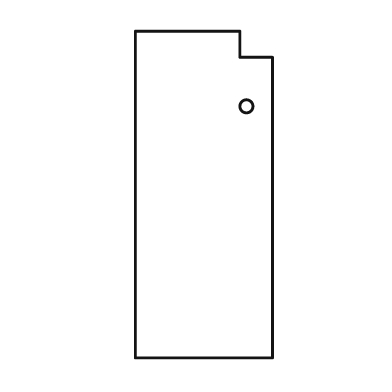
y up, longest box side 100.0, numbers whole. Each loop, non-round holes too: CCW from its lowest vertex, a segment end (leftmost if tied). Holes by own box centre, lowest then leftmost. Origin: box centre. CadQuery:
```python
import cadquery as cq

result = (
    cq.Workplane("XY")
    .moveTo(-21.0, -50.0)
    .lineTo(21.0, -50.0)
    .lineTo(21.0, 42.0)
    .lineTo(11.0, 42.0)
    .lineTo(11.0, 50.0)
    .lineTo(-21.0, 50.0)
    .close()
    .moveTo(13.0, 27.0)
    .circle(2.0)
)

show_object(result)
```